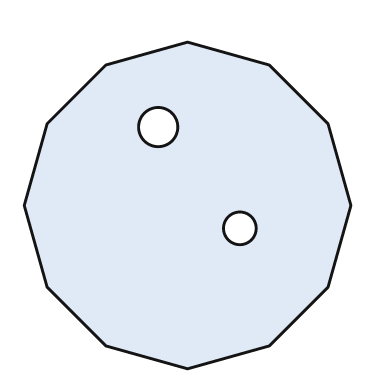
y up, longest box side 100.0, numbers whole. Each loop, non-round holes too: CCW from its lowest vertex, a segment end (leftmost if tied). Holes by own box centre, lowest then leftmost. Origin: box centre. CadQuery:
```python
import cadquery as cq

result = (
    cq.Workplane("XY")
    .moveTo(0.0, -50.0)
    .lineTo(25.0, -43.0)
    .lineTo(43.0, -25.0)
    .lineTo(50.0, 0.0)
    .lineTo(43.0, 25.0)
    .lineTo(25.0, 43.0)
    .lineTo(0.0, 50.0)
    .lineTo(-25.0, 43.0)
    .lineTo(-43.0, 25.0)
    .lineTo(-50.0, 0.0)
    .lineTo(-43.0, -25.0)
    .lineTo(-25.0, -43.0)
    .close()
    .moveTo(16.0, -7.0)
    .circle(5.0)
    .moveTo(-9.0, 24.0)
    .circle(6.0)
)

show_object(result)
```